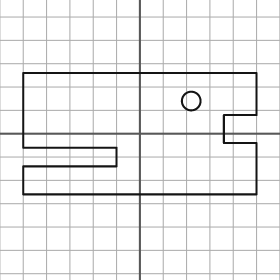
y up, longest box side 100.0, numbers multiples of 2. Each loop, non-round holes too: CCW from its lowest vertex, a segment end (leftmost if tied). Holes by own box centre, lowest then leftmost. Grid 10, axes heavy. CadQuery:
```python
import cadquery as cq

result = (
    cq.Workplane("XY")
    .moveTo(-50.0, -26.0)
    .lineTo(50.0, -26.0)
    .lineTo(50.0, -4.0)
    .lineTo(36.0, -4.0)
    .lineTo(36.0, 8.0)
    .lineTo(50.0, 8.0)
    .lineTo(50.0, 26.0)
    .lineTo(-50.0, 26.0)
    .lineTo(-50.0, -6.0)
    .lineTo(-10.0, -6.0)
    .lineTo(-10.0, -14.0)
    .lineTo(-50.0, -14.0)
    .close()
    .moveTo(22.0, 14.0)
    .circle(4.0)
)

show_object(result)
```